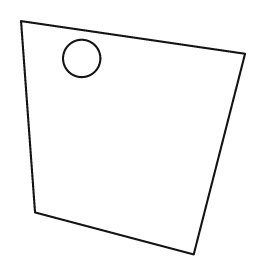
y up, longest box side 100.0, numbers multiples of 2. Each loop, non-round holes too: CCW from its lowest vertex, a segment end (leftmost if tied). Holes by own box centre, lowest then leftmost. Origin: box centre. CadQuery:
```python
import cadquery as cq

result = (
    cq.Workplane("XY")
    .moveTo(26.0, -50.0)
    .lineTo(48.0, 36.0)
    .lineTo(-48.0, 50.0)
    .lineTo(-42.0, -32.0)
    .close()
    .moveTo(-22.0, 34.0)
    .circle(8.0)
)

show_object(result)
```